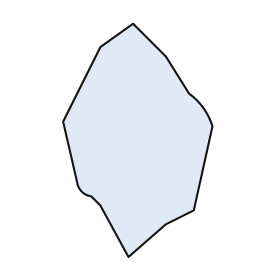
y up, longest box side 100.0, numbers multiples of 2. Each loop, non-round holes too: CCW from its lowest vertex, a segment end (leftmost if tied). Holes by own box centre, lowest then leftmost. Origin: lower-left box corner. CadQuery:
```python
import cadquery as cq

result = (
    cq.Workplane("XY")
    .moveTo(28.0, 0.0)
    .lineTo(44.0, 14.0)
    .lineTo(56.0, 20.0)
    .lineTo(64.0, 56.0)
    .threePointArc((60.0, 64.0), (54.0, 70.0))
    .lineTo(44.0, 86.0)
    .lineTo(30.0, 100.0)
    .lineTo(16.0, 90.0)
    .lineTo(0.0, 58.0)
    .lineTo(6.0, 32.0)
    .threePointArc((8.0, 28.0), (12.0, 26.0))
    .lineTo(16.0, 22.0)
    .close()
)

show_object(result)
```